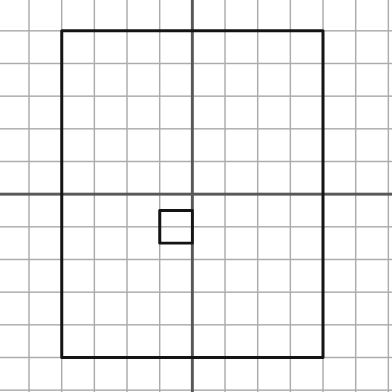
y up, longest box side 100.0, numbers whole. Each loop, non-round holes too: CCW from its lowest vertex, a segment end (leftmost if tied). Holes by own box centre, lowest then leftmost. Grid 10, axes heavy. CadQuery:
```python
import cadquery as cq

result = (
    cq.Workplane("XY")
    .moveTo(-40.0, -50.0)
    .lineTo(40.0, -50.0)
    .lineTo(40.0, 50.0)
    .lineTo(-40.0, 50.0)
    .close()
    .moveTo(-10.0, -15.0)
    .lineTo(0.0, -15.0)
    .lineTo(0.0, -5.0)
    .lineTo(-10.0, -5.0)
    .close()
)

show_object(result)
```